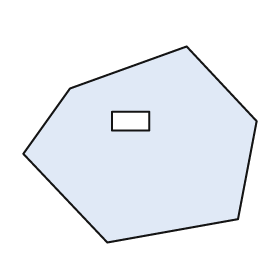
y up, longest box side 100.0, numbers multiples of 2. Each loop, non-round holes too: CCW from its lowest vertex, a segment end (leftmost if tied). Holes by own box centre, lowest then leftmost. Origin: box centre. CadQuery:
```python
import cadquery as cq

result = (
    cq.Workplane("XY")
    .moveTo(-14.0, -42.0)
    .lineTo(42.0, -32.0)
    .lineTo(50.0, 10.0)
    .lineTo(20.0, 42.0)
    .lineTo(-30.0, 24.0)
    .lineTo(-50.0, -4.0)
    .close()
    .moveTo(-12.0, 6.0)
    .lineTo(4.0, 6.0)
    .lineTo(4.0, 14.0)
    .lineTo(-12.0, 14.0)
    .close()
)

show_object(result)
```